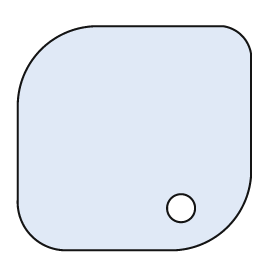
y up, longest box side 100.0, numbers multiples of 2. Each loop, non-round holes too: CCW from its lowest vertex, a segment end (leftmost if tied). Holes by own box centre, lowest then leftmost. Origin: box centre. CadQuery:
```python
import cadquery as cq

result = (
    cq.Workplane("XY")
    .moveTo(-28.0, -48.0)
    .lineTo(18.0, -48.0)
    .threePointArc((40.0, -38.0), (50.0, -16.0))
    .lineTo(50.0, 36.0)
    .threePointArc((46.0, 44.0), (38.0, 48.0))
    .lineTo(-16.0, 48.0)
    .threePointArc((-40.0, 38.0), (-50.0, 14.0))
    .lineTo(-50.0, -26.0)
    .threePointArc((-44.0, -42.0), (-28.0, -48.0))
    .close()
    .moveTo(20.0, -30.0)
    .circle(6.0)
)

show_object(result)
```